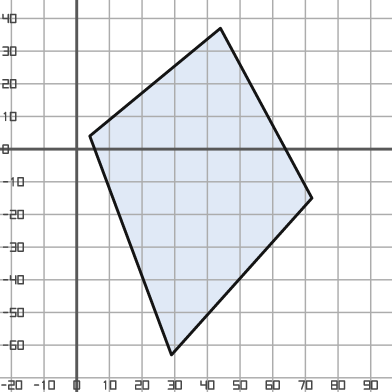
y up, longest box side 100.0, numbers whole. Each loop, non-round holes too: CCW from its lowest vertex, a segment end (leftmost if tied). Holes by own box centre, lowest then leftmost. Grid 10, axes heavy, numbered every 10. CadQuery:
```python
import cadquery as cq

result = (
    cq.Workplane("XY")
    .moveTo(29.0, -63.0)
    .lineTo(72.0, -15.0)
    .lineTo(44.0, 37.0)
    .lineTo(4.0, 4.0)
    .close()
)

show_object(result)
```